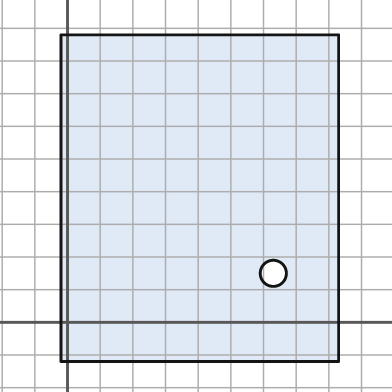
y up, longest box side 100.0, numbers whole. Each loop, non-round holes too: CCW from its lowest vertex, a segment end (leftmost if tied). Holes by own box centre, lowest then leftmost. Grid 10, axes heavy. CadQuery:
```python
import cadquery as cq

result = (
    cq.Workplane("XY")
    .moveTo(-2.0, -12.0)
    .lineTo(83.0, -12.0)
    .lineTo(83.0, 88.0)
    .lineTo(-2.0, 88.0)
    .close()
    .moveTo(63.0, 15.0)
    .circle(4.0)
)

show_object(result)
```